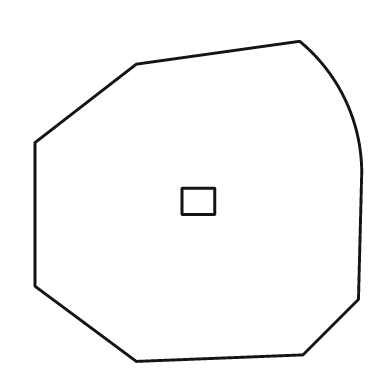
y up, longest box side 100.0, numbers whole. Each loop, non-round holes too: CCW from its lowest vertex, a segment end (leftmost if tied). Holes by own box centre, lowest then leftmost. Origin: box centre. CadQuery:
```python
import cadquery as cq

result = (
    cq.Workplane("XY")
    .moveTo(-19.0, -49.0)
    .lineTo(32.0, -47.0)
    .lineTo(49.0, -30.0)
    .lineTo(50.0, 9.0)
    .threePointArc((45.0, 31.0), (31.0, 49.0))
    .lineTo(-19.0, 42.0)
    .lineTo(-50.0, 18.0)
    .lineTo(-50.0, -26.0)
    .close()
    .moveTo(-5.0, -4.0)
    .lineTo(5.0, -4.0)
    .lineTo(5.0, 4.0)
    .lineTo(-5.0, 4.0)
    .close()
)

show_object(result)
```